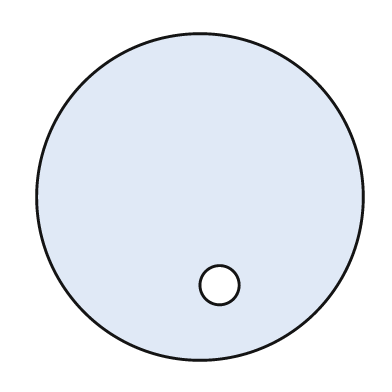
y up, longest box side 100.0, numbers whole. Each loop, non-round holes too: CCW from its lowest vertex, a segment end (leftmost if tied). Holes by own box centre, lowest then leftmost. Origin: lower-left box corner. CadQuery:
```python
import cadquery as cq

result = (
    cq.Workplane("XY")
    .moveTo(50.0, 50.0)
    .circle(50.0)
    .moveTo(56.0, 23.0)
    .circle(6.0)
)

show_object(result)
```